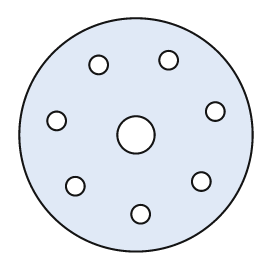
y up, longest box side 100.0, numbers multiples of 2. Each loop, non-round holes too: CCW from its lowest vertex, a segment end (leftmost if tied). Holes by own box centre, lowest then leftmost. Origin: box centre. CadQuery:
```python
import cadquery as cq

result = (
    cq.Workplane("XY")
    .moveTo(0.0, 0.0)
    .circle(50.0)
    .moveTo(2.0, -34.0)
    .circle(4.0)
    .moveTo(-26.0, -22.0)
    .circle(4.0)
    .moveTo(28.0, -20.0)
    .circle(4.0)
    .moveTo(0.0, 0.0)
    .circle(8.0)
    .moveTo(-34.0, 6.0)
    .circle(4.0)
    .moveTo(34.0, 10.0)
    .circle(4.0)
    .moveTo(-16.0, 30.0)
    .circle(4.0)
    .moveTo(14.0, 32.0)
    .circle(4.0)
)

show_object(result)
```